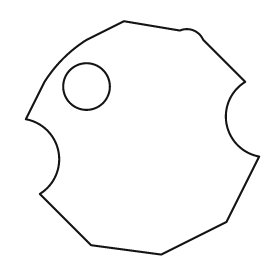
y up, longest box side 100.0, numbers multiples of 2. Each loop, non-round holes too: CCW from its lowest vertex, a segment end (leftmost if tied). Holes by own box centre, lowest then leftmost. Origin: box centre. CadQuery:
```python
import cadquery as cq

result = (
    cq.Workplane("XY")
    .moveTo(8.0, -50.0)
    .lineTo(36.0, -36.0)
    .lineTo(50.0, -8.0)
    .threePointArc((36.0, 6.0), (44.0, 24.0))
    .lineTo(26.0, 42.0)
    .threePointArc((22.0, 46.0), (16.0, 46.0))
    .lineTo(-8.0, 50.0)
    .lineTo(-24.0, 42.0)
    .threePointArc((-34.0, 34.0), (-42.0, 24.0))
    .lineTo(-50.0, 8.0)
    .threePointArc((-36.0, -6.0), (-44.0, -24.0))
    .lineTo(-22.0, -46.0)
    .close()
    .moveTo(-24.0, 22.0)
    .circle(10.0)
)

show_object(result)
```